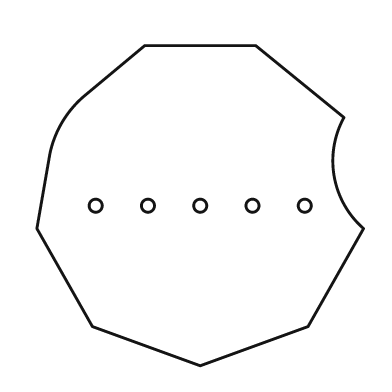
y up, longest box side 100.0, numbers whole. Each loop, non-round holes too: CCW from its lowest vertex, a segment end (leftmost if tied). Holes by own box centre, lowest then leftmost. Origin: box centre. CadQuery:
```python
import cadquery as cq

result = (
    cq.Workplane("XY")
    .moveTo(0.0, -49.0)
    .lineTo(33.0, -37.0)
    .lineTo(50.0, -7.0)
    .threePointArc((41.0, 9.0), (44.0, 27.0))
    .lineTo(17.0, 49.0)
    .lineTo(-17.0, 49.0)
    .lineTo(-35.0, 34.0)
    .threePointArc((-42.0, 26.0), (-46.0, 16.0))
    .lineTo(-50.0, -7.0)
    .lineTo(-33.0, -37.0)
    .close()
    .moveTo(-32.0, 0.0)
    .circle(2.0)
    .moveTo(-16.0, 0.0)
    .circle(2.0)
    .moveTo(0.0, 0.0)
    .circle(2.0)
    .moveTo(16.0, 0.0)
    .circle(2.0)
    .moveTo(32.0, 0.0)
    .circle(2.0)
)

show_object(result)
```